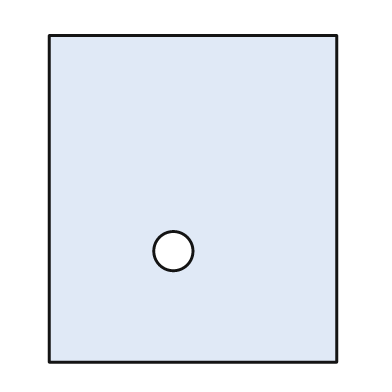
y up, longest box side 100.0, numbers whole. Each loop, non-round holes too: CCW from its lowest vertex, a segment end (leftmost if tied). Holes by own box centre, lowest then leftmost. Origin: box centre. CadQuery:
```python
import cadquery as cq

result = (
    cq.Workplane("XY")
    .moveTo(-44.0, -50.0)
    .lineTo(44.0, -50.0)
    .lineTo(44.0, 50.0)
    .lineTo(-44.0, 50.0)
    .close()
    .moveTo(-6.0, -16.0)
    .circle(6.0)
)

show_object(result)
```